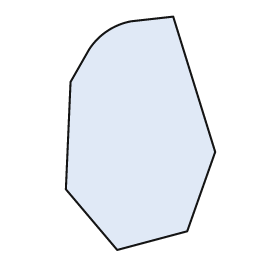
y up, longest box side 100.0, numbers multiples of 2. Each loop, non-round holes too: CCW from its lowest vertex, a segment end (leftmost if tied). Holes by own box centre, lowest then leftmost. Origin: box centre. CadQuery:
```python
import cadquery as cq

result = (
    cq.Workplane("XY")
    .moveTo(-10.0, -50.0)
    .lineTo(20.0, -42.0)
    .lineTo(32.0, -8.0)
    .lineTo(14.0, 50.0)
    .lineTo(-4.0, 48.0)
    .threePointArc((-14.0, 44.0), (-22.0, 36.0))
    .lineTo(-30.0, 22.0)
    .lineTo(-32.0, -24.0)
    .close()
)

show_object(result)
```